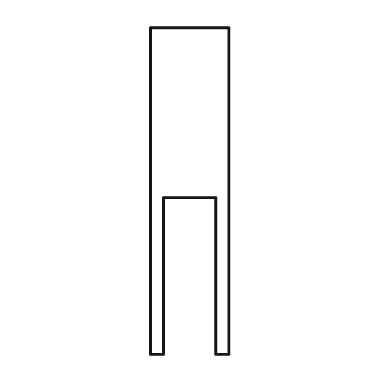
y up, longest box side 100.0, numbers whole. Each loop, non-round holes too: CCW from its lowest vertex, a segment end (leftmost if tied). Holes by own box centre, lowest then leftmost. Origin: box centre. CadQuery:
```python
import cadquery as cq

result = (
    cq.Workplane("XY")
    .moveTo(-12.0, -50.0)
    .lineTo(-8.0, -50.0)
    .lineTo(-8.0, -2.0)
    .lineTo(8.0, -2.0)
    .lineTo(8.0, -50.0)
    .lineTo(12.0, -50.0)
    .lineTo(12.0, 50.0)
    .lineTo(-12.0, 50.0)
    .close()
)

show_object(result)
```